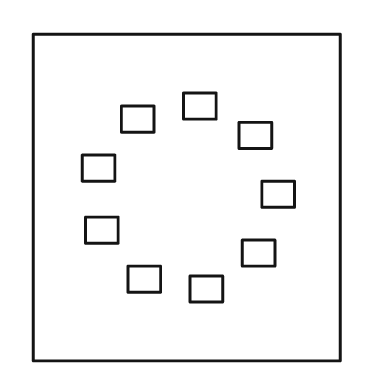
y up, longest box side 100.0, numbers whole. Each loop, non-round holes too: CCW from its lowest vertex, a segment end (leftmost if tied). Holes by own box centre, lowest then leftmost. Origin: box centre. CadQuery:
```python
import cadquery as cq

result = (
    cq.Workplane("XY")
    .moveTo(-47.0, -50.0)
    .lineTo(47.0, -50.0)
    .lineTo(47.0, 50.0)
    .lineTo(-47.0, 50.0)
    .close()
    .moveTo(1.0, -32.0)
    .lineTo(11.0, -32.0)
    .lineTo(11.0, -24.0)
    .lineTo(1.0, -24.0)
    .close()
    .moveTo(-18.0, -29.0)
    .lineTo(-8.0, -29.0)
    .lineTo(-8.0, -21.0)
    .lineTo(-18.0, -21.0)
    .close()
    .moveTo(17.0, -21.0)
    .lineTo(27.0, -21.0)
    .lineTo(27.0, -13.0)
    .lineTo(17.0, -13.0)
    .close()
    .moveTo(-31.0, -14.0)
    .lineTo(-21.0, -14.0)
    .lineTo(-21.0, -6.0)
    .lineTo(-31.0, -6.0)
    .close()
    .moveTo(23.0, -3.0)
    .lineTo(33.0, -3.0)
    .lineTo(33.0, 5.0)
    .lineTo(23.0, 5.0)
    .close()
    .moveTo(-32.0, 5.0)
    .lineTo(-22.0, 5.0)
    .lineTo(-22.0, 13.0)
    .lineTo(-32.0, 13.0)
    .close()
    .moveTo(16.0, 15.0)
    .lineTo(26.0, 15.0)
    .lineTo(26.0, 23.0)
    .lineTo(16.0, 23.0)
    .close()
    .moveTo(-20.0, 20.0)
    .lineTo(-10.0, 20.0)
    .lineTo(-10.0, 28.0)
    .lineTo(-20.0, 28.0)
    .close()
    .moveTo(-1.0, 24.0)
    .lineTo(9.0, 24.0)
    .lineTo(9.0, 32.0)
    .lineTo(-1.0, 32.0)
    .close()
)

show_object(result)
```